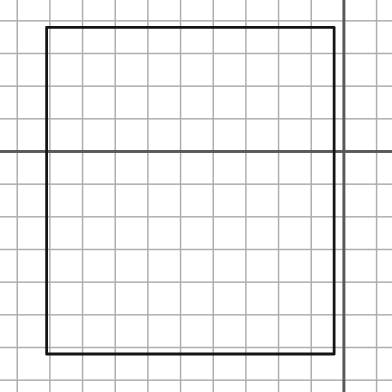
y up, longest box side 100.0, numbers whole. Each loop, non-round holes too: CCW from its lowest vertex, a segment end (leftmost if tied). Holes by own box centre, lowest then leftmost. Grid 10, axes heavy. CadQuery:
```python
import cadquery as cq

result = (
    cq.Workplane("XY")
    .moveTo(-91.0, -62.0)
    .lineTo(-3.0, -62.0)
    .lineTo(-3.0, 38.0)
    .lineTo(-91.0, 38.0)
    .close()
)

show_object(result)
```